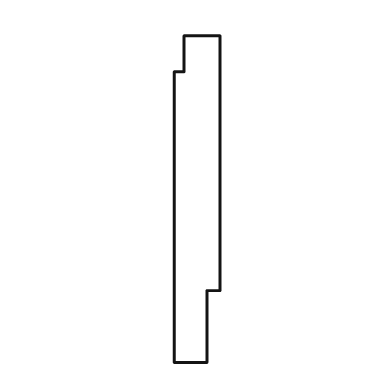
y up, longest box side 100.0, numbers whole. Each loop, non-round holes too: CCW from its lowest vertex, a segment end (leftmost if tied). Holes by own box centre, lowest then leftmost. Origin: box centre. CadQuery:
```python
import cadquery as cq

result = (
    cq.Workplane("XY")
    .moveTo(-7.0, -50.0)
    .lineTo(3.0, -50.0)
    .lineTo(3.0, -28.0)
    .lineTo(7.0, -28.0)
    .lineTo(7.0, 50.0)
    .lineTo(-4.0, 50.0)
    .lineTo(-4.0, 39.0)
    .lineTo(-7.0, 39.0)
    .close()
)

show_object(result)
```